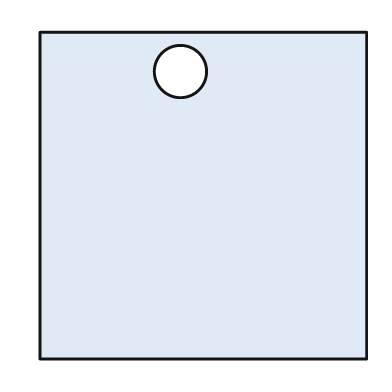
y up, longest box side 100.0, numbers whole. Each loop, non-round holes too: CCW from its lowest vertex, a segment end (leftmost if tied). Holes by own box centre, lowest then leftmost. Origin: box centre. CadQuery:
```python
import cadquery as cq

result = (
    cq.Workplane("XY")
    .moveTo(-50.0, -50.0)
    .lineTo(50.0, -50.0)
    .lineTo(50.0, 50.0)
    .lineTo(-50.0, 50.0)
    .close()
    .moveTo(-7.0, 38.0)
    .circle(8.0)
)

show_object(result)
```